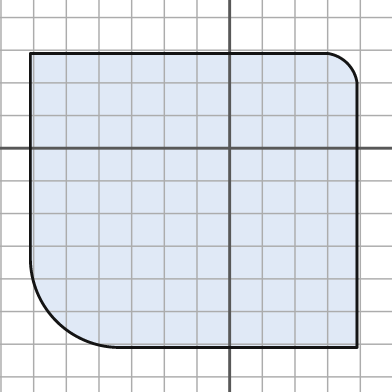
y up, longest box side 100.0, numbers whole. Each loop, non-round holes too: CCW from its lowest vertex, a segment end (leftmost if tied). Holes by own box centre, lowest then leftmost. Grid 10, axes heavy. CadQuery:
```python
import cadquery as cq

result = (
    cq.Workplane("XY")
    .moveTo(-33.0, -61.0)
    .lineTo(39.0, -61.0)
    .lineTo(39.0, 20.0)
    .threePointArc((36.0, 26.0), (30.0, 29.0))
    .lineTo(-61.0, 29.0)
    .lineTo(-61.0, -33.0)
    .threePointArc((-53.0, -53.0), (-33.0, -61.0))
    .close()
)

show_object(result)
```